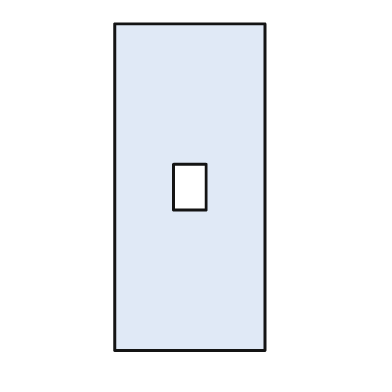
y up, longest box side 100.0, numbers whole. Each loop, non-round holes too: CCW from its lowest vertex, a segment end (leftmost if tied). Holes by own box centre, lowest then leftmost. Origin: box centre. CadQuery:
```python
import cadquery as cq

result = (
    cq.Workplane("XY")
    .moveTo(-23.0, -50.0)
    .lineTo(23.0, -50.0)
    .lineTo(23.0, 50.0)
    .lineTo(-23.0, 50.0)
    .close()
    .moveTo(-5.0, -7.0)
    .lineTo(5.0, -7.0)
    .lineTo(5.0, 7.0)
    .lineTo(-5.0, 7.0)
    .close()
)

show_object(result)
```